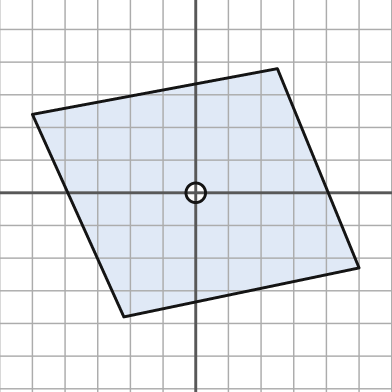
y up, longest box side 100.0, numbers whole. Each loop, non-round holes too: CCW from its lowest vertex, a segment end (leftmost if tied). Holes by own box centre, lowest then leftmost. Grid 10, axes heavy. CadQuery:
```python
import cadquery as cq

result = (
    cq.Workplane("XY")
    .moveTo(-22.0, -38.0)
    .lineTo(50.0, -23.0)
    .lineTo(25.0, 38.0)
    .lineTo(-50.0, 24.0)
    .close()
    .moveTo(0.0, 0.0)
    .circle(3.0)
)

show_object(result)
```